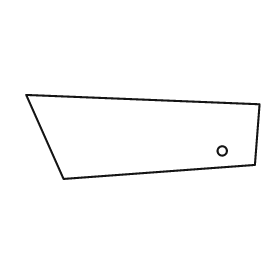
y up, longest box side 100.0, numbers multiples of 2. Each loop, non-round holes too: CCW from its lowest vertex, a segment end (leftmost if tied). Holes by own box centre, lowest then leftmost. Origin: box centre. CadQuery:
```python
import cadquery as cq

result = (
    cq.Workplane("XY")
    .moveTo(-34.0, -18.0)
    .lineTo(48.0, -12.0)
    .lineTo(50.0, 14.0)
    .lineTo(-50.0, 18.0)
    .close()
    .moveTo(34.0, -6.0)
    .circle(2.0)
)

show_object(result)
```